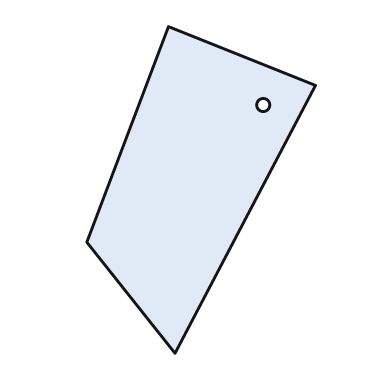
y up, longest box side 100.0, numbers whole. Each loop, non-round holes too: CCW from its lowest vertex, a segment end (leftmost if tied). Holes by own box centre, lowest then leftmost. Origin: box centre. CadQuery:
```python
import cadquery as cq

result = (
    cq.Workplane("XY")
    .moveTo(-8.0, -50.0)
    .lineTo(35.0, 32.0)
    .lineTo(-10.0, 50.0)
    .lineTo(-35.0, -16.0)
    .close()
    .moveTo(19.0, 26.0)
    .circle(2.0)
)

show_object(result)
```